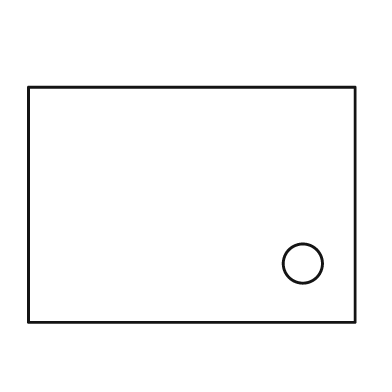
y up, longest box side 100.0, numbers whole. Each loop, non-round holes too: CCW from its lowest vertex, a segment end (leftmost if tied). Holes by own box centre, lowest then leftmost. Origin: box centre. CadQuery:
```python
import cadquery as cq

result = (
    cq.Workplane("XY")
    .moveTo(-50.0, -36.0)
    .lineTo(50.0, -36.0)
    .lineTo(50.0, 36.0)
    .lineTo(-50.0, 36.0)
    .close()
    .moveTo(34.0, -18.0)
    .circle(6.0)
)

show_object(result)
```